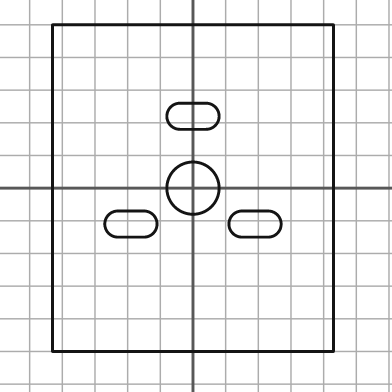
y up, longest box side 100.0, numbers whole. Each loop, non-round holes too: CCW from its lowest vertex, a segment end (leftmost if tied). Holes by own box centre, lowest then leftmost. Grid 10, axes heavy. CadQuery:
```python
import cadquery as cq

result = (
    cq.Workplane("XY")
    .moveTo(-43.0, -50.0)
    .lineTo(43.0, -50.0)
    .lineTo(43.0, 50.0)
    .lineTo(-43.0, 50.0)
    .close()
    .moveTo(-23.0, -15.0)
    .lineTo(-15.0, -15.0)
    .threePointArc((-11.0, -11.0), (-15.0, -7.0))
    .lineTo(-23.0, -7.0)
    .threePointArc((-27.0, -11.0), (-23.0, -15.0))
    .close()
    .moveTo(15.0, -15.0)
    .lineTo(23.0, -15.0)
    .threePointArc((27.0, -11.0), (23.0, -7.0))
    .lineTo(15.0, -7.0)
    .threePointArc((11.0, -11.0), (15.0, -15.0))
    .close()
    .moveTo(0.0, 0.0)
    .circle(8.0)
    .moveTo(-4.0, 18.0)
    .lineTo(4.0, 18.0)
    .threePointArc((8.0, 22.0), (4.0, 26.0))
    .lineTo(-4.0, 26.0)
    .threePointArc((-8.0, 22.0), (-4.0, 18.0))
    .close()
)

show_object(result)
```